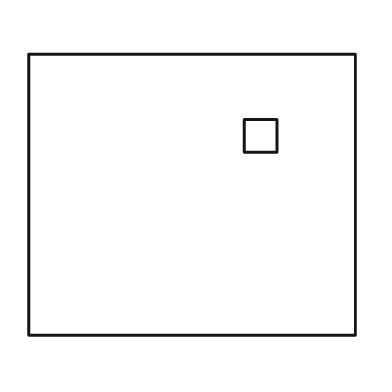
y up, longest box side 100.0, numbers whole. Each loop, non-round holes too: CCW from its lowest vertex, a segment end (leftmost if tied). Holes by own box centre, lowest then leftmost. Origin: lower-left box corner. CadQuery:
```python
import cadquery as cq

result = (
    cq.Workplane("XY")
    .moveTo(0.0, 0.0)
    .lineTo(100.0, 0.0)
    .lineTo(100.0, 86.0)
    .lineTo(0.0, 86.0)
    .close()
    .moveTo(66.0, 56.0)
    .lineTo(76.0, 56.0)
    .lineTo(76.0, 66.0)
    .lineTo(66.0, 66.0)
    .close()
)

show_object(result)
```